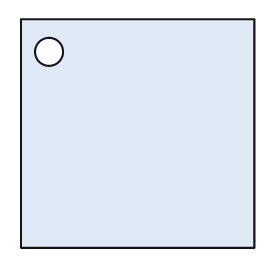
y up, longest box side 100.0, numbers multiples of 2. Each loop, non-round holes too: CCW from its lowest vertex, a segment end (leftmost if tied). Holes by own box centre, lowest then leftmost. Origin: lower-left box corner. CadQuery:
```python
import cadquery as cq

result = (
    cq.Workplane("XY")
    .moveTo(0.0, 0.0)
    .lineTo(100.0, 0.0)
    .lineTo(100.0, 98.0)
    .lineTo(0.0, 98.0)
    .close()
    .moveTo(12.0, 84.0)
    .circle(6.0)
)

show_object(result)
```